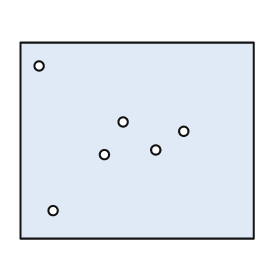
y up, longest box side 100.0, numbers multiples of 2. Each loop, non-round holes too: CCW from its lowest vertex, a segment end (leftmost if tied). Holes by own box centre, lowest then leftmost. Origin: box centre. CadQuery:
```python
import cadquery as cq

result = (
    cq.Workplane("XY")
    .moveTo(-50.0, -42.0)
    .lineTo(50.0, -42.0)
    .lineTo(50.0, 42.0)
    .lineTo(-50.0, 42.0)
    .close()
    .moveTo(-36.0, -30.0)
    .circle(2.0)
    .moveTo(-14.0, -6.0)
    .circle(2.0)
    .moveTo(8.0, -4.0)
    .circle(2.0)
    .moveTo(20.0, 4.0)
    .circle(2.0)
    .moveTo(-6.0, 8.0)
    .circle(2.0)
    .moveTo(-42.0, 32.0)
    .circle(2.0)
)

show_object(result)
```